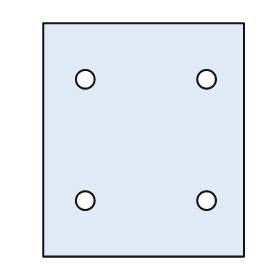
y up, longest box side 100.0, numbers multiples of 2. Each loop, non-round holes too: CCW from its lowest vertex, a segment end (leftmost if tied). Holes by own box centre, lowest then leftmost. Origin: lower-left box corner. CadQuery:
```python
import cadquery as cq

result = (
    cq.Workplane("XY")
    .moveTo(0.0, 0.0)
    .lineTo(86.0, 0.0)
    .lineTo(86.0, 100.0)
    .lineTo(0.0, 100.0)
    .close()
    .moveTo(18.0, 24.0)
    .circle(4.0)
    .moveTo(70.0, 24.0)
    .circle(4.0)
    .moveTo(18.0, 76.0)
    .circle(4.0)
    .moveTo(70.0, 76.0)
    .circle(4.0)
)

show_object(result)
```